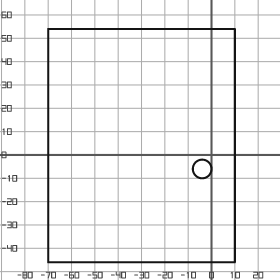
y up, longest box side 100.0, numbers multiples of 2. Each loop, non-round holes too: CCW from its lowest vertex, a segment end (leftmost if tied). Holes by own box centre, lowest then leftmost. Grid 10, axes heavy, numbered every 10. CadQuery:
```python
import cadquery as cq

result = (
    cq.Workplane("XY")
    .moveTo(-70.0, -46.0)
    .lineTo(10.0, -46.0)
    .lineTo(10.0, 54.0)
    .lineTo(-70.0, 54.0)
    .close()
    .moveTo(-4.0, -6.0)
    .circle(4.0)
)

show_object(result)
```